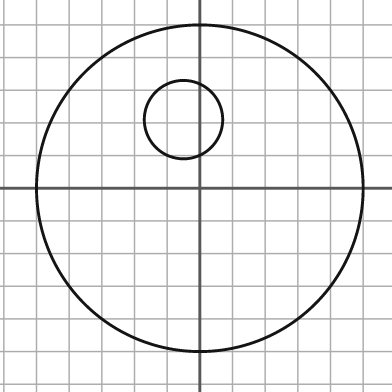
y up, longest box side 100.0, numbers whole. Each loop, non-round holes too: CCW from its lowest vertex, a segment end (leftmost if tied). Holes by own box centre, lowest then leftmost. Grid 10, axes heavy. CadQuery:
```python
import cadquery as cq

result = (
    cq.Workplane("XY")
    .moveTo(0.0, 0.0)
    .circle(50.0)
    .moveTo(-5.0, 21.0)
    .circle(12.0)
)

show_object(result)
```